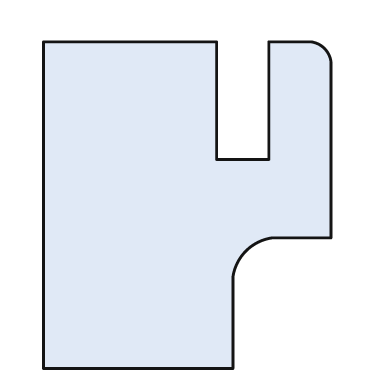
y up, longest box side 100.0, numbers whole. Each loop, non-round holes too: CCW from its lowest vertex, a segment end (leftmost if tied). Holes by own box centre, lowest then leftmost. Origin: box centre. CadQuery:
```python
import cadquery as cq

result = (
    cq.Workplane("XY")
    .moveTo(-44.0, -50.0)
    .lineTo(14.0, -50.0)
    .lineTo(14.0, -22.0)
    .threePointArc((18.0, -14.0), (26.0, -10.0))
    .lineTo(44.0, -10.0)
    .lineTo(44.0, 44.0)
    .threePointArc((42.0, 48.0), (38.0, 50.0))
    .lineTo(25.0, 50.0)
    .lineTo(25.0, 14.0)
    .lineTo(9.0, 14.0)
    .lineTo(9.0, 50.0)
    .lineTo(-44.0, 50.0)
    .close()
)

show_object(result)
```